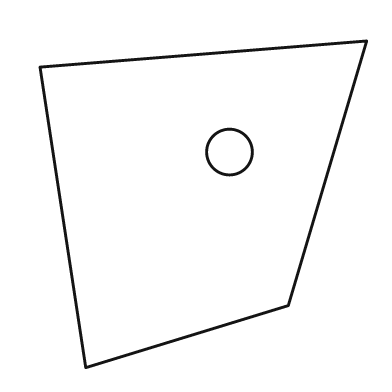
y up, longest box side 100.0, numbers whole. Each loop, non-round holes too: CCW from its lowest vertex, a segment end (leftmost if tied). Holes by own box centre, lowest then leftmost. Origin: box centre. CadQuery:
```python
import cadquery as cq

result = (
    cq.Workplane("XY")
    .moveTo(-36.0, -50.0)
    .lineTo(26.0, -31.0)
    .lineTo(50.0, 50.0)
    .lineTo(-50.0, 42.0)
    .close()
    .moveTo(8.0, 16.0)
    .circle(7.0)
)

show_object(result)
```